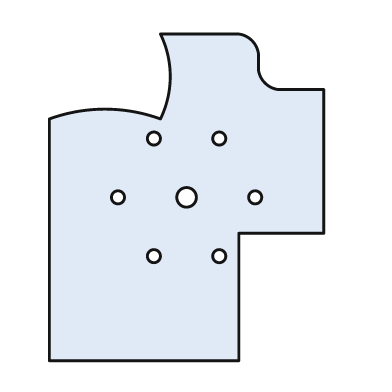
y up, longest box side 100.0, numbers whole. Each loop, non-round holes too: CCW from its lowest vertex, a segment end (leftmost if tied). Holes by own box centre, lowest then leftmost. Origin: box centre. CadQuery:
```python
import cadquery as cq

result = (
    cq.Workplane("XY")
    .moveTo(-42.0, -50.0)
    .lineTo(16.0, -50.0)
    .lineTo(16.0, -11.0)
    .lineTo(42.0, -11.0)
    .lineTo(42.0, 33.0)
    .lineTo(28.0, 33.0)
    .threePointArc((24.0, 35.0), (22.0, 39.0))
    .lineTo(22.0, 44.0)
    .threePointArc((20.0, 48.0), (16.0, 50.0))
    .lineTo(-8.0, 50.0)
    .threePointArc((-5.0, 37.0), (-8.0, 24.0))
    .threePointArc((-25.0, 27.0), (-42.0, 24.0))
    .close()
    .moveTo(-10.0, -18.0)
    .circle(2.0)
    .moveTo(10.0, -18.0)
    .circle(2.0)
    .moveTo(-21.0, 0.0)
    .circle(2.0)
    .moveTo(0.0, 0.0)
    .circle(3.0)
    .moveTo(21.0, 0.0)
    .circle(2.0)
    .moveTo(-10.0, 18.0)
    .circle(2.0)
    .moveTo(10.0, 18.0)
    .circle(2.0)
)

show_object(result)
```